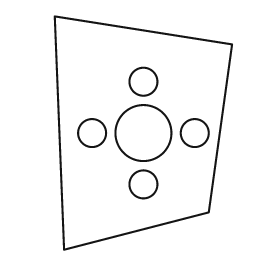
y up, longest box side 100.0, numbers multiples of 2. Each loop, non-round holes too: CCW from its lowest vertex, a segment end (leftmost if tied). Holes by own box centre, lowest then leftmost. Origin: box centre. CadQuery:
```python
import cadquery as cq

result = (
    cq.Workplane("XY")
    .moveTo(-34.0, -50.0)
    .lineTo(28.0, -34.0)
    .lineTo(38.0, 38.0)
    .lineTo(-38.0, 50.0)
    .close()
    .moveTo(0.0, -22.0)
    .circle(6.0)
    .moveTo(-22.0, 0.0)
    .circle(6.0)
    .moveTo(0.0, 0.0)
    .circle(12.0)
    .moveTo(22.0, 0.0)
    .circle(6.0)
    .moveTo(0.0, 22.0)
    .circle(6.0)
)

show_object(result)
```